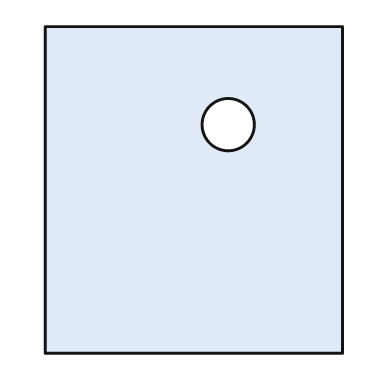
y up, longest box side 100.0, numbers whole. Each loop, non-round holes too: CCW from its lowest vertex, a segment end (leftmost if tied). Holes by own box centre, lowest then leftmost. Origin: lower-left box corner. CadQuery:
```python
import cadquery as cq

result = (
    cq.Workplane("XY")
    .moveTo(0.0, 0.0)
    .lineTo(91.0, 0.0)
    .lineTo(91.0, 100.0)
    .lineTo(0.0, 100.0)
    .close()
    .moveTo(56.0, 70.0)
    .circle(8.0)
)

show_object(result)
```